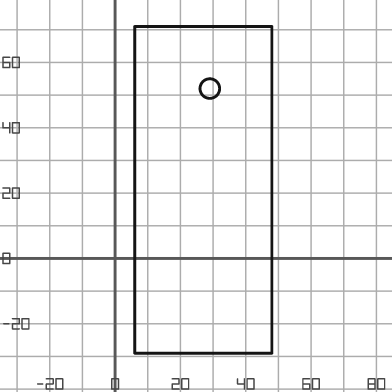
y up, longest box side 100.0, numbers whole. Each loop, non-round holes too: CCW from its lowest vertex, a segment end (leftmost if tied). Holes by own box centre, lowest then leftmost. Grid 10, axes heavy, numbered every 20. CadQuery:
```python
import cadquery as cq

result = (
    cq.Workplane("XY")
    .moveTo(6.0, -29.0)
    .lineTo(48.0, -29.0)
    .lineTo(48.0, 71.0)
    .lineTo(6.0, 71.0)
    .close()
    .moveTo(29.0, 52.0)
    .circle(3.0)
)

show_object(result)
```